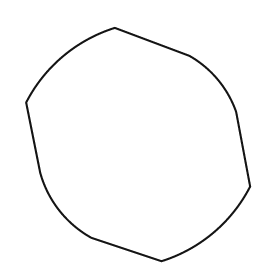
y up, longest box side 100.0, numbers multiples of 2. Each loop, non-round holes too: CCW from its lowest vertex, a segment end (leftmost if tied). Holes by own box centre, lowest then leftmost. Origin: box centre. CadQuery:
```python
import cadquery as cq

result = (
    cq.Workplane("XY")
    .moveTo(10.0, -50.0)
    .threePointArc((32.0, -38.0), (48.0, -18.0))
    .lineTo(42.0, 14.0)
    .threePointArc((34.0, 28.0), (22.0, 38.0))
    .lineTo(-10.0, 50.0)
    .threePointArc((-32.0, 38.0), (-48.0, 18.0))
    .lineTo(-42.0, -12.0)
    .threePointArc((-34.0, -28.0), (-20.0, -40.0))
    .close()
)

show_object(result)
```